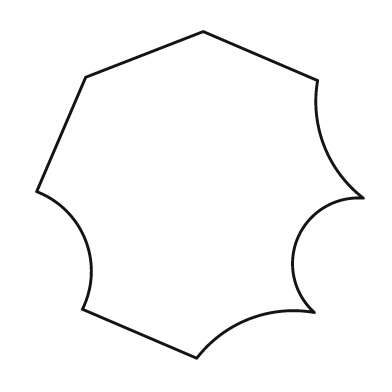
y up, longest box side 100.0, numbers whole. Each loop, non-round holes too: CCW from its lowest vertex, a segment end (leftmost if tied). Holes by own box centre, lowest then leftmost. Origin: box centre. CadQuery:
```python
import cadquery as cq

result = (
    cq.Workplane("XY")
    .moveTo(-1.0, -50.0)
    .threePointArc((15.0, -38.0), (35.0, -36.0))
    .threePointArc((30.0, -13.0), (50.0, -1.0))
    .threePointArc((38.0, 15.0), (36.0, 35.0))
    .lineTo(1.0, 50.0)
    .lineTo(-35.0, 36.0)
    .lineTo(-50.0, 1.0)
    .threePointArc((-35.0, -14.0), (-36.0, -35.0))
    .close()
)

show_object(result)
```